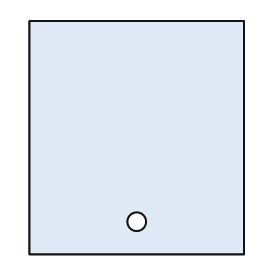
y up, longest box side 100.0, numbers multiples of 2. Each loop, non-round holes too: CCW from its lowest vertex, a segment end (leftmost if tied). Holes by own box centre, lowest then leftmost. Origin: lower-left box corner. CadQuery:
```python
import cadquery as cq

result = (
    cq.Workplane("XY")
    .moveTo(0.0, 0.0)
    .lineTo(92.0, 0.0)
    .lineTo(92.0, 100.0)
    .lineTo(0.0, 100.0)
    .close()
    .moveTo(46.0, 14.0)
    .circle(4.0)
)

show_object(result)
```